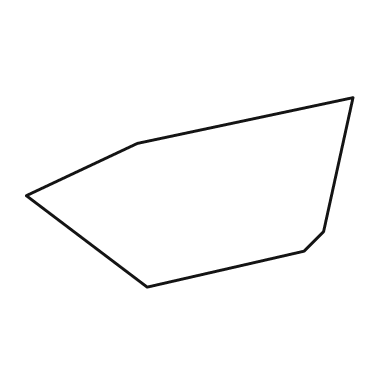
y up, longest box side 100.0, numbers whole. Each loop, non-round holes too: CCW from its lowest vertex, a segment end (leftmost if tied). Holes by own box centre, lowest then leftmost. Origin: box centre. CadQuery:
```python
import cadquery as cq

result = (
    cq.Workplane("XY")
    .moveTo(-13.0, -29.0)
    .lineTo(35.0, -18.0)
    .lineTo(41.0, -12.0)
    .lineTo(50.0, 29.0)
    .lineTo(-16.0, 15.0)
    .lineTo(-50.0, -1.0)
    .close()
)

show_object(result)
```